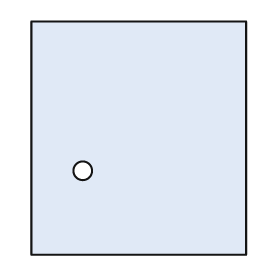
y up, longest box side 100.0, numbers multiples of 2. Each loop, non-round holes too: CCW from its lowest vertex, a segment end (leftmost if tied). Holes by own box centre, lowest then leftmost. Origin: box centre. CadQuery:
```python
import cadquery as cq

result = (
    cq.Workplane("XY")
    .moveTo(-46.0, -50.0)
    .lineTo(46.0, -50.0)
    .lineTo(46.0, 50.0)
    .lineTo(-46.0, 50.0)
    .close()
    .moveTo(-24.0, -14.0)
    .circle(4.0)
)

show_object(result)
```